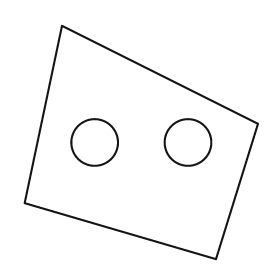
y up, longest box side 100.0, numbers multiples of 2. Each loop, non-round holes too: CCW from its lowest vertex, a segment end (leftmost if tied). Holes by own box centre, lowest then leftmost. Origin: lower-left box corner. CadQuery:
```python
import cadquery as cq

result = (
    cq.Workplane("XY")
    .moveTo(82.0, 0.0)
    .lineTo(100.0, 58.0)
    .lineTo(16.0, 100.0)
    .lineTo(0.0, 24.0)
    .close()
    .moveTo(30.0, 50.0)
    .circle(10.0)
    .moveTo(70.0, 50.0)
    .circle(10.0)
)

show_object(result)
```